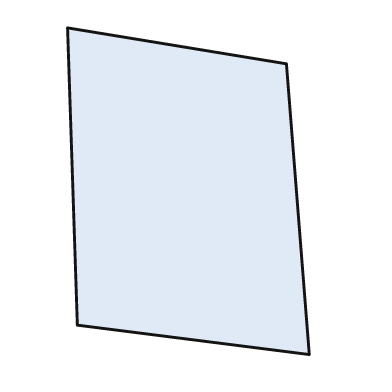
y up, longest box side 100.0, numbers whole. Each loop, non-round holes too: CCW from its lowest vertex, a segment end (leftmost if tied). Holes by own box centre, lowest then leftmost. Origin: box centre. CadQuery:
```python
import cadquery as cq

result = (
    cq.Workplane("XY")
    .moveTo(37.0, -50.0)
    .lineTo(30.0, 39.0)
    .lineTo(-37.0, 50.0)
    .lineTo(-34.0, -41.0)
    .close()
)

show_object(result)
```